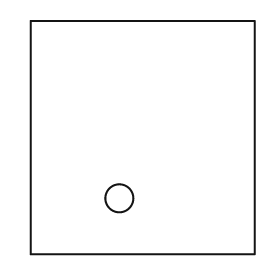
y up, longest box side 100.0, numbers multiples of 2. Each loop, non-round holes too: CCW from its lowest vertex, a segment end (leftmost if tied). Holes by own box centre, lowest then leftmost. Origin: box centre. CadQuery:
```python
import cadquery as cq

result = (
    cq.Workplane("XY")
    .moveTo(-48.0, -50.0)
    .lineTo(48.0, -50.0)
    .lineTo(48.0, 50.0)
    .lineTo(-48.0, 50.0)
    .close()
    .moveTo(-10.0, -26.0)
    .circle(6.0)
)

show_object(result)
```